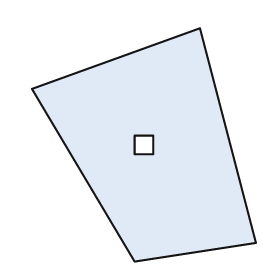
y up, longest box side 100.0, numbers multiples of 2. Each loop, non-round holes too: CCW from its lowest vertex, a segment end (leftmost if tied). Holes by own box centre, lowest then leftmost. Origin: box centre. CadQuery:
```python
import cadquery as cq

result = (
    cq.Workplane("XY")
    .moveTo(-4.0, -50.0)
    .lineTo(48.0, -42.0)
    .lineTo(24.0, 50.0)
    .lineTo(-48.0, 24.0)
    .close()
    .moveTo(-4.0, -4.0)
    .lineTo(4.0, -4.0)
    .lineTo(4.0, 4.0)
    .lineTo(-4.0, 4.0)
    .close()
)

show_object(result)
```